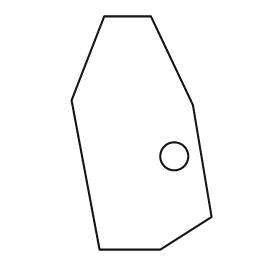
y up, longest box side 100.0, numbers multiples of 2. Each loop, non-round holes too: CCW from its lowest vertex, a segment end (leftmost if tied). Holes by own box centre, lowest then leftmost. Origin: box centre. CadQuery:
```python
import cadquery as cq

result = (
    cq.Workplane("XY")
    .moveTo(-18.0, -50.0)
    .lineTo(8.0, -50.0)
    .lineTo(30.0, -36.0)
    .lineTo(22.0, 12.0)
    .lineTo(4.0, 50.0)
    .lineTo(-16.0, 50.0)
    .lineTo(-30.0, 14.0)
    .close()
    .moveTo(14.0, -10.0)
    .circle(6.0)
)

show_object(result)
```